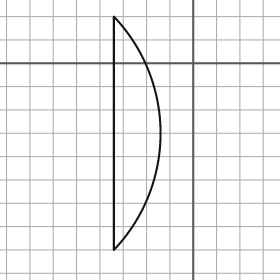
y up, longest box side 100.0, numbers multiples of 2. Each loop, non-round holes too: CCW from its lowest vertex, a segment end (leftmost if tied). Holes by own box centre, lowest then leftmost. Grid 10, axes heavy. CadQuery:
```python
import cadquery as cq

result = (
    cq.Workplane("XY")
    .moveTo(-34.0, -80.0)
    .threePointArc((-14.0, -30.0), (-34.0, 20.0))
    .close()
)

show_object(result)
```